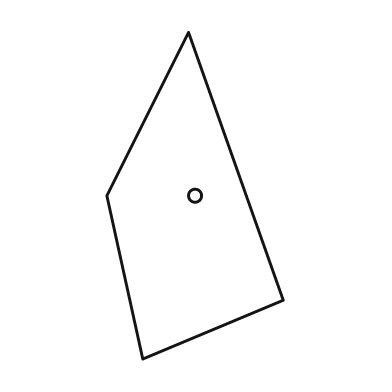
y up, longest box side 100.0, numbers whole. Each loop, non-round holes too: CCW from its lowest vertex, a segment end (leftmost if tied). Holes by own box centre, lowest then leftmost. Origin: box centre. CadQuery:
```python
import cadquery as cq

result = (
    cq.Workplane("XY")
    .moveTo(-16.0, -50.0)
    .lineTo(27.0, -32.0)
    .lineTo(-2.0, 50.0)
    .lineTo(-27.0, 0.0)
    .close()
    .moveTo(0.0, 0.0)
    .circle(2.0)
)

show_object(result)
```